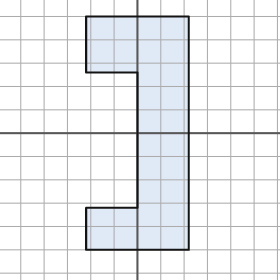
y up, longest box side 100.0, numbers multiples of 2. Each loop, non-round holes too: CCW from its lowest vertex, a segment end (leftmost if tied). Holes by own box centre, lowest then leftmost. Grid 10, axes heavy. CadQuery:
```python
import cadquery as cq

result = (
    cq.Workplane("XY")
    .moveTo(-22.0, -50.0)
    .lineTo(22.0, -50.0)
    .lineTo(22.0, 50.0)
    .lineTo(-22.0, 50.0)
    .lineTo(-22.0, 26.0)
    .lineTo(0.0, 26.0)
    .lineTo(0.0, -32.0)
    .lineTo(-22.0, -32.0)
    .close()
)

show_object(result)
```